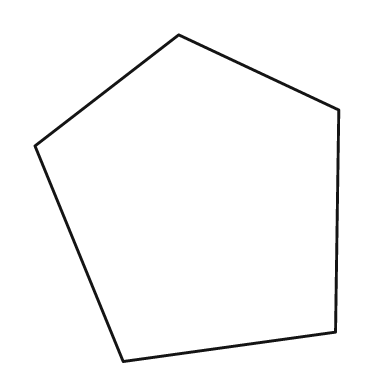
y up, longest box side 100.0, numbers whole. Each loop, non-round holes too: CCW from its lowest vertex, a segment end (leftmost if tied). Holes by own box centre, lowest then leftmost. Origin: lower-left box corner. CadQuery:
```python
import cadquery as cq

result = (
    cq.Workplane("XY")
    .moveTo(27.0, 0.0)
    .lineTo(92.0, 9.0)
    .lineTo(93.0, 77.0)
    .lineTo(44.0, 100.0)
    .lineTo(0.0, 66.0)
    .close()
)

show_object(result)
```